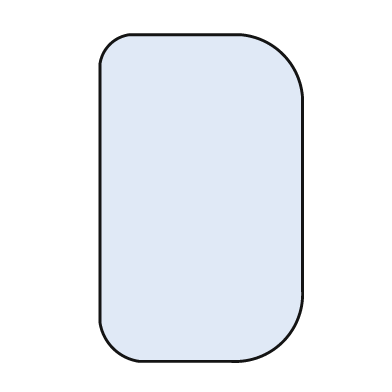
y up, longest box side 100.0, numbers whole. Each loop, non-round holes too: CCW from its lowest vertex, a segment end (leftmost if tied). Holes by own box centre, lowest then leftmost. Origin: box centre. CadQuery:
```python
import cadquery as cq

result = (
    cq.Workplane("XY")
    .moveTo(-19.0, -50.0)
    .lineTo(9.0, -50.0)
    .threePointArc((25.0, -44.0), (31.0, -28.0))
    .lineTo(31.0, 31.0)
    .threePointArc((25.0, 44.0), (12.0, 50.0))
    .lineTo(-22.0, 50.0)
    .threePointArc((-28.0, 47.0), (-31.0, 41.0))
    .lineTo(-31.0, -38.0)
    .threePointArc((-27.0, -46.0), (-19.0, -50.0))
    .close()
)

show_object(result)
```